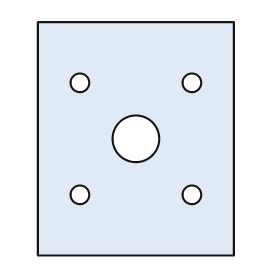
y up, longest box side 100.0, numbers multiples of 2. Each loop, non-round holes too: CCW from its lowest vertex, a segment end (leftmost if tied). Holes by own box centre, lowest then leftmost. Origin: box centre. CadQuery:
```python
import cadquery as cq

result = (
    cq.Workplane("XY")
    .moveTo(-42.0, -50.0)
    .lineTo(42.0, -50.0)
    .lineTo(42.0, 50.0)
    .lineTo(-42.0, 50.0)
    .close()
    .moveTo(-24.0, -24.0)
    .circle(4.0)
    .moveTo(24.0, -24.0)
    .circle(4.0)
    .moveTo(0.0, 0.0)
    .circle(10.0)
    .moveTo(-24.0, 24.0)
    .circle(4.0)
    .moveTo(24.0, 24.0)
    .circle(4.0)
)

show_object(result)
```